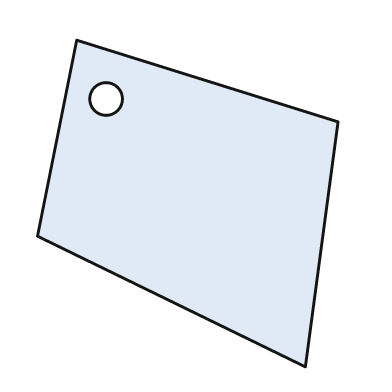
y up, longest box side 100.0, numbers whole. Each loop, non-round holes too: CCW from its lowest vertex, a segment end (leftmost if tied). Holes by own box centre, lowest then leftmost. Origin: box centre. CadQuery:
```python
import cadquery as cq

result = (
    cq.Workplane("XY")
    .moveTo(36.0, -50.0)
    .lineTo(46.0, 25.0)
    .lineTo(-34.0, 50.0)
    .lineTo(-46.0, -10.0)
    .close()
    .moveTo(-25.0, 32.0)
    .circle(5.0)
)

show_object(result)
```